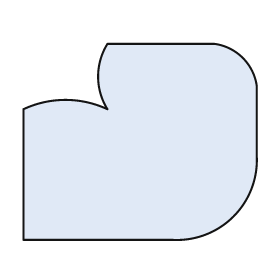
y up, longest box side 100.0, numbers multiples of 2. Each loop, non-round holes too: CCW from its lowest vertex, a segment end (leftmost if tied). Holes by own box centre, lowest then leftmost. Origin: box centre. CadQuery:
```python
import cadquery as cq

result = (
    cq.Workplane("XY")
    .moveTo(-50.0, -42.0)
    .lineTo(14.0, -42.0)
    .threePointArc((40.0, -32.0), (50.0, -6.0))
    .lineTo(50.0, 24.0)
    .threePointArc((44.0, 36.0), (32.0, 42.0))
    .lineTo(-14.0, 42.0)
    .threePointArc((-18.0, 28.0), (-14.0, 14.0))
    .threePointArc((-32.0, 18.0), (-50.0, 14.0))
    .close()
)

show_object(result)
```